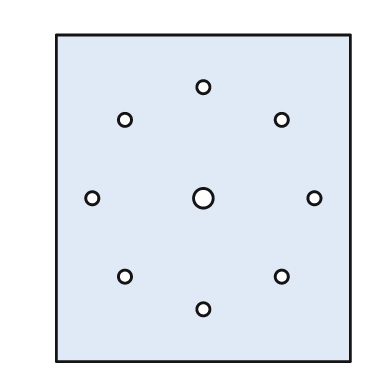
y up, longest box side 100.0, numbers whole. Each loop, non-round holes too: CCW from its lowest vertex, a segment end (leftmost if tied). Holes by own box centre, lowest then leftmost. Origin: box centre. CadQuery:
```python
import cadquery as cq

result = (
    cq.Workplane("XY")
    .moveTo(-45.0, -50.0)
    .lineTo(45.0, -50.0)
    .lineTo(45.0, 50.0)
    .lineTo(-45.0, 50.0)
    .close()
    .moveTo(0.0, -34.0)
    .circle(2.0)
    .moveTo(-24.0, -24.0)
    .circle(2.0)
    .moveTo(24.0, -24.0)
    .circle(2.0)
    .moveTo(-34.0, 0.0)
    .circle(2.0)
    .moveTo(0.0, 0.0)
    .circle(3.0)
    .moveTo(34.0, 0.0)
    .circle(2.0)
    .moveTo(-24.0, 24.0)
    .circle(2.0)
    .moveTo(24.0, 24.0)
    .circle(2.0)
    .moveTo(0.0, 34.0)
    .circle(2.0)
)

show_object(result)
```